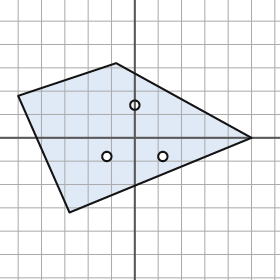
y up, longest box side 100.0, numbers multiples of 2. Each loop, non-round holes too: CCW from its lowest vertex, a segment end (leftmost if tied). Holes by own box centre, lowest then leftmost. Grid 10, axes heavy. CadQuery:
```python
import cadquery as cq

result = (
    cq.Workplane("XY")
    .moveTo(-28.0, -32.0)
    .lineTo(50.0, 0.0)
    .lineTo(-8.0, 32.0)
    .lineTo(-50.0, 18.0)
    .close()
    .moveTo(-12.0, -8.0)
    .circle(2.0)
    .moveTo(12.0, -8.0)
    .circle(2.0)
    .moveTo(0.0, 14.0)
    .circle(2.0)
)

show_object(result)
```